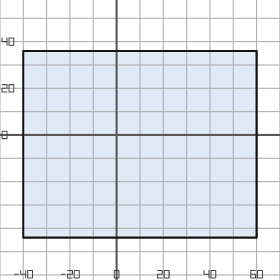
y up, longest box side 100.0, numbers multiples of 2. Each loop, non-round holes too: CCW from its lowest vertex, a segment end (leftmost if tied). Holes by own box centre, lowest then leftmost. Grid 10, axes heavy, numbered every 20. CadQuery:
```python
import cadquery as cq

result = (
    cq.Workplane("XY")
    .moveTo(-40.0, -44.0)
    .lineTo(60.0, -44.0)
    .lineTo(60.0, 36.0)
    .lineTo(-40.0, 36.0)
    .close()
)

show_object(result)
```